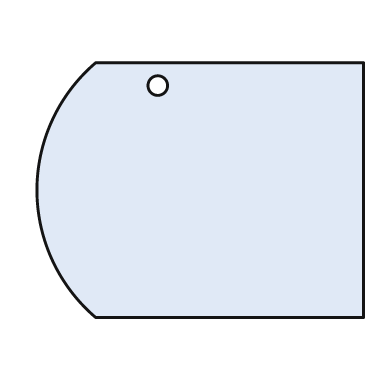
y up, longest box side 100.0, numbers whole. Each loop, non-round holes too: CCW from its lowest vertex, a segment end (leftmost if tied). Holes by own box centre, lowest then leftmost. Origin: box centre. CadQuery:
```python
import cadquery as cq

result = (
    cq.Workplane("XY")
    .moveTo(-32.0, -39.0)
    .lineTo(50.0, -39.0)
    .lineTo(50.0, 39.0)
    .lineTo(-32.0, 39.0)
    .threePointArc((-50.0, 0.0), (-32.0, -39.0))
    .close()
    .moveTo(-13.0, 32.0)
    .circle(3.0)
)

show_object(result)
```